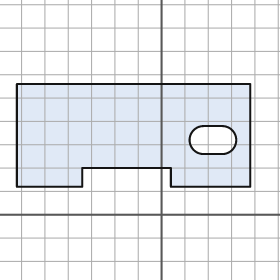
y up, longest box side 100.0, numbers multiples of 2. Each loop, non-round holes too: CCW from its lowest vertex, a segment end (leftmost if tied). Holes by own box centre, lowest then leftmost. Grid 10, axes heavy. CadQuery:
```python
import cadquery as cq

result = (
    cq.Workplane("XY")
    .moveTo(-62.0, 12.0)
    .lineTo(-34.0, 12.0)
    .lineTo(-34.0, 20.0)
    .lineTo(4.0, 20.0)
    .lineTo(4.0, 12.0)
    .lineTo(38.0, 12.0)
    .lineTo(38.0, 56.0)
    .lineTo(-62.0, 56.0)
    .close()
    .moveTo(18.0, 26.0)
    .lineTo(26.0, 26.0)
    .threePointArc((32.0, 32.0), (26.0, 38.0))
    .lineTo(18.0, 38.0)
    .threePointArc((12.0, 32.0), (18.0, 26.0))
    .close()
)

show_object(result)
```